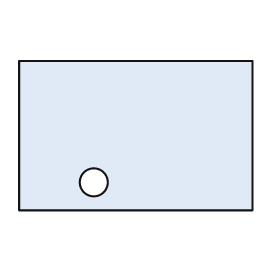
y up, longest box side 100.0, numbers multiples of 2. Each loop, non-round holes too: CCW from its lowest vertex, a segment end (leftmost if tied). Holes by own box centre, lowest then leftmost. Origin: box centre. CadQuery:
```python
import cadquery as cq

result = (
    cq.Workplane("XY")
    .moveTo(-50.0, -32.0)
    .lineTo(50.0, -32.0)
    .lineTo(50.0, 32.0)
    .lineTo(-50.0, 32.0)
    .close()
    .moveTo(-18.0, -20.0)
    .circle(6.0)
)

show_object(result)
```